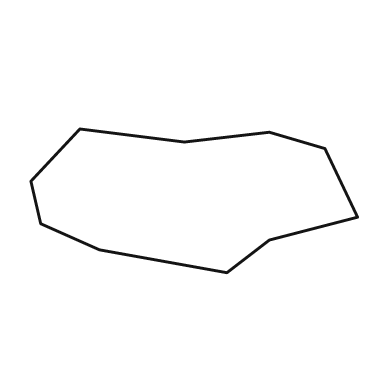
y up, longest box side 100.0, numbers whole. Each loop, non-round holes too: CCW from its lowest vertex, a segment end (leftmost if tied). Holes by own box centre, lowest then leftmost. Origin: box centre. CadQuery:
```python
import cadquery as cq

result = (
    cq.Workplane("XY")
    .moveTo(10.0, -22.0)
    .lineTo(23.0, -12.0)
    .lineTo(50.0, -5.0)
    .lineTo(40.0, 16.0)
    .lineTo(23.0, 21.0)
    .lineTo(-3.0, 18.0)
    .lineTo(-35.0, 22.0)
    .lineTo(-50.0, 6.0)
    .lineTo(-47.0, -7.0)
    .lineTo(-29.0, -15.0)
    .close()
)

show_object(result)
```